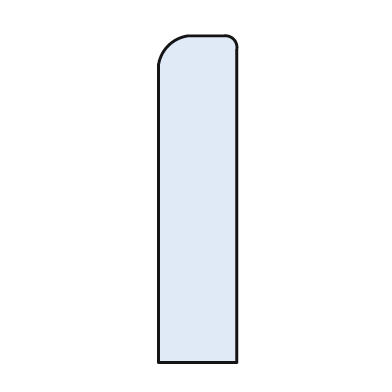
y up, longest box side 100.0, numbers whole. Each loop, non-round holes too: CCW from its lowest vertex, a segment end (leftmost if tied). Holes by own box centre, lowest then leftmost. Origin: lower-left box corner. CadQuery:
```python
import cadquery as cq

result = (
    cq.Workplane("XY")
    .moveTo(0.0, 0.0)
    .lineTo(24.0, 0.0)
    .lineTo(24.0, 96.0)
    .threePointArc((23.0, 99.0), (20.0, 100.0))
    .lineTo(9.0, 100.0)
    .threePointArc((3.0, 97.0), (0.0, 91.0))
    .close()
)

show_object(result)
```